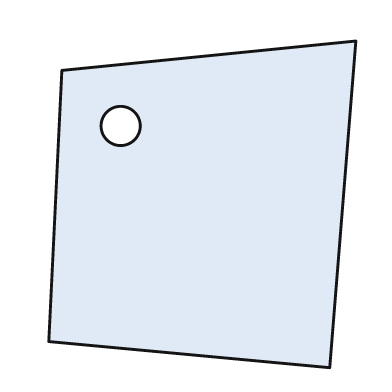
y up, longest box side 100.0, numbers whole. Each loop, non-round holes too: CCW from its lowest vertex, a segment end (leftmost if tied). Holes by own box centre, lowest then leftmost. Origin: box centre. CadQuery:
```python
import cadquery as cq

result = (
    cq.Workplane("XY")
    .moveTo(39.0, -50.0)
    .lineTo(47.0, 50.0)
    .lineTo(-43.0, 41.0)
    .lineTo(-47.0, -42.0)
    .close()
    .moveTo(-25.0, 24.0)
    .circle(6.0)
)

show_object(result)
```